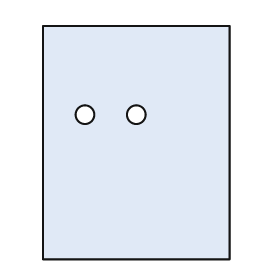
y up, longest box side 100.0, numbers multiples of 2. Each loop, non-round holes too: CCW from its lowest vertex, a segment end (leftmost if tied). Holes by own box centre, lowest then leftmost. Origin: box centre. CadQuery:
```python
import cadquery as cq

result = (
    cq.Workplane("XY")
    .moveTo(-40.0, -50.0)
    .lineTo(40.0, -50.0)
    .lineTo(40.0, 50.0)
    .lineTo(-40.0, 50.0)
    .close()
    .moveTo(-22.0, 12.0)
    .circle(4.0)
    .moveTo(0.0, 12.0)
    .circle(4.0)
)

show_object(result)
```